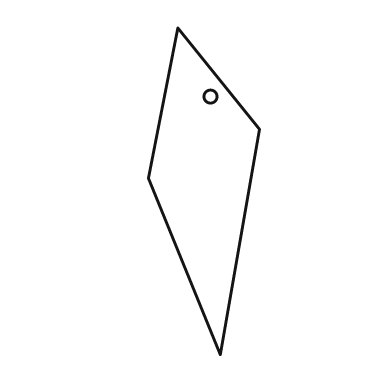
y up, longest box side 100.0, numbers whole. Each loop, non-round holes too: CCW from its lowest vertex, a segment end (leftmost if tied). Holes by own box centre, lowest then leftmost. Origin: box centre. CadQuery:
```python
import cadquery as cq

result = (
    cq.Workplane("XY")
    .moveTo(5.0, -50.0)
    .lineTo(17.0, 19.0)
    .lineTo(-8.0, 50.0)
    .lineTo(-17.0, 4.0)
    .close()
    .moveTo(2.0, 29.0)
    .circle(2.0)
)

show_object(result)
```